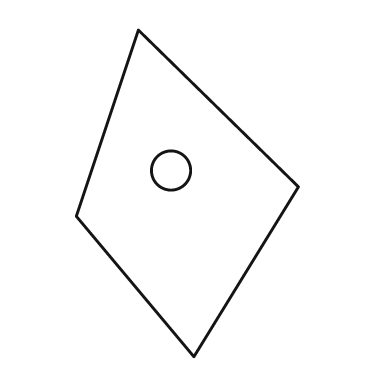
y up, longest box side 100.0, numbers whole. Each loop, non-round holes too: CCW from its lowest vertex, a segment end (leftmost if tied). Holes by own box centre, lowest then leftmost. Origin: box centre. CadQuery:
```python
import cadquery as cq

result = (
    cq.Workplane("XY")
    .moveTo(2.0, -50.0)
    .lineTo(34.0, 2.0)
    .lineTo(-15.0, 50.0)
    .lineTo(-34.0, -7.0)
    .close()
    .moveTo(-5.0, 7.0)
    .circle(6.0)
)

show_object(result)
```